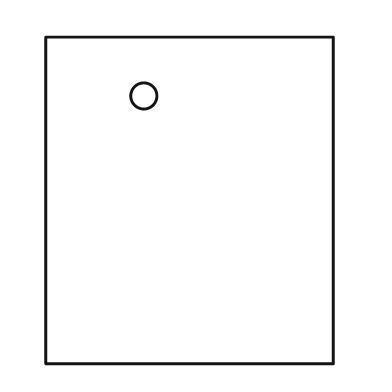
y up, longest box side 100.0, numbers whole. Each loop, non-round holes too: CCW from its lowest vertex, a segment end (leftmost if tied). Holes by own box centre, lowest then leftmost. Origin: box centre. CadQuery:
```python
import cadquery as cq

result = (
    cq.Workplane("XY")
    .moveTo(-44.0, -50.0)
    .lineTo(44.0, -50.0)
    .lineTo(44.0, 50.0)
    .lineTo(-44.0, 50.0)
    .close()
    .moveTo(-14.0, 32.0)
    .circle(4.0)
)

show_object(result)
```